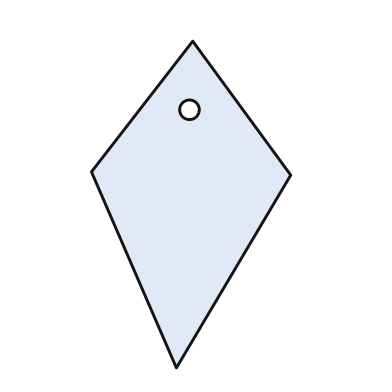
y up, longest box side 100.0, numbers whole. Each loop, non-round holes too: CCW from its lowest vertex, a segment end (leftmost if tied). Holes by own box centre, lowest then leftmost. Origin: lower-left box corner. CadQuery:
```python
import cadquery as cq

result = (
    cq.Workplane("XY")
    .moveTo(26.0, 0.0)
    .lineTo(61.0, 59.0)
    .lineTo(31.0, 100.0)
    .lineTo(0.0, 60.0)
    .close()
    .moveTo(30.0, 79.0)
    .circle(3.0)
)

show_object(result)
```